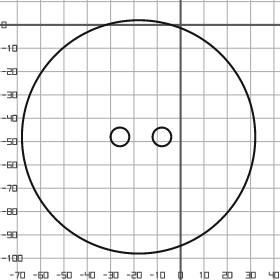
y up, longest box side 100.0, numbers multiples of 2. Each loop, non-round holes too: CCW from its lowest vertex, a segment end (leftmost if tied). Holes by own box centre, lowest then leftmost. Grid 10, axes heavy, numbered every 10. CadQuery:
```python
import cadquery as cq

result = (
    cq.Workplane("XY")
    .moveTo(-18.0, -48.0)
    .circle(50.0)
    .moveTo(-26.0, -48.0)
    .circle(4.0)
    .moveTo(-8.0, -48.0)
    .circle(4.0)
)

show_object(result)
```